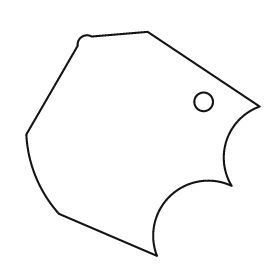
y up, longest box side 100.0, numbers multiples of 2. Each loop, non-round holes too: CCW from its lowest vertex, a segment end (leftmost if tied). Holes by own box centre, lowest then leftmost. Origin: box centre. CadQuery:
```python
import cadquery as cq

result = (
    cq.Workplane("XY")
    .moveTo(6.0, -48.0)
    .threePointArc((12.0, -22.0), (38.0, -18.0))
    .threePointArc((36.0, 2.0), (50.0, 16.0))
    .lineTo(2.0, 48.0)
    .lineTo(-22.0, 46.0)
    .threePointArc((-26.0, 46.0), (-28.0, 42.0))
    .lineTo(-50.0, 4.0)
    .threePointArc((-46.0, -14.0), (-36.0, -30.0))
    .close()
    .moveTo(26.0, 18.0)
    .circle(4.0)
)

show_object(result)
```